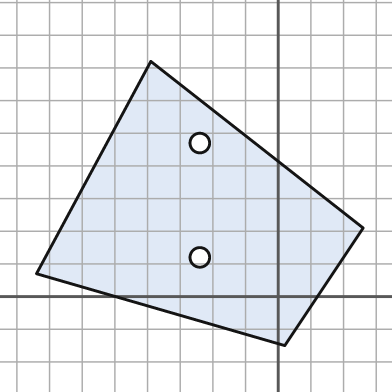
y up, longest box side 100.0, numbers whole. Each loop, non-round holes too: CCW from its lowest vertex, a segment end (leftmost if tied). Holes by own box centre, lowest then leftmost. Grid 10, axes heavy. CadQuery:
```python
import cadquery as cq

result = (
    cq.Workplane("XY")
    .moveTo(2.0, -15.0)
    .lineTo(26.0, 21.0)
    .lineTo(-39.0, 72.0)
    .lineTo(-74.0, 7.0)
    .close()
    .moveTo(-24.0, 12.0)
    .circle(3.0)
    .moveTo(-24.0, 47.0)
    .circle(3.0)
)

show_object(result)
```